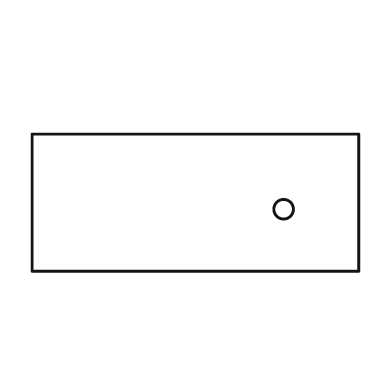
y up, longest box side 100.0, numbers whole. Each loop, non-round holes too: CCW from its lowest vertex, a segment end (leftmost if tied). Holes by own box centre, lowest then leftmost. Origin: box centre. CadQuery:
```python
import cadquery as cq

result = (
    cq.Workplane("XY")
    .moveTo(-50.0, -21.0)
    .lineTo(50.0, -21.0)
    .lineTo(50.0, 21.0)
    .lineTo(-50.0, 21.0)
    .close()
    .moveTo(27.0, -2.0)
    .circle(3.0)
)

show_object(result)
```